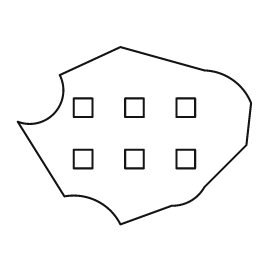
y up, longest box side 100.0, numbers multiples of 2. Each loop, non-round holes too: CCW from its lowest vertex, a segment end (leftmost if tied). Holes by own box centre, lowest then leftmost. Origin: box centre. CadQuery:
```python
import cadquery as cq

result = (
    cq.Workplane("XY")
    .moveTo(-6.0, -38.0)
    .lineTo(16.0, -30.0)
    .threePointArc((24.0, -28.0), (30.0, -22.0))
    .lineTo(48.0, -4.0)
    .lineTo(50.0, 14.0)
    .threePointArc((42.0, 24.0), (30.0, 28.0))
    .lineTo(-6.0, 38.0)
    .lineTo(-32.0, 26.0)
    .threePointArc((-34.0, 10.0), (-50.0, 6.0))
    .lineTo(-30.0, -26.0)
    .threePointArc((-16.0, -28.0), (-6.0, -38.0))
    .close()
    .moveTo(-26.0, -14.0)
    .lineTo(-18.0, -14.0)
    .lineTo(-18.0, -6.0)
    .lineTo(-26.0, -6.0)
    .close()
    .moveTo(-4.0, -14.0)
    .lineTo(4.0, -14.0)
    .lineTo(4.0, -6.0)
    .lineTo(-4.0, -6.0)
    .close()
    .moveTo(18.0, -14.0)
    .lineTo(26.0, -14.0)
    .lineTo(26.0, -6.0)
    .lineTo(18.0, -6.0)
    .close()
    .moveTo(-26.0, 8.0)
    .lineTo(-18.0, 8.0)
    .lineTo(-18.0, 16.0)
    .lineTo(-26.0, 16.0)
    .close()
    .moveTo(-4.0, 8.0)
    .lineTo(4.0, 8.0)
    .lineTo(4.0, 16.0)
    .lineTo(-4.0, 16.0)
    .close()
    .moveTo(18.0, 8.0)
    .lineTo(26.0, 8.0)
    .lineTo(26.0, 16.0)
    .lineTo(18.0, 16.0)
    .close()
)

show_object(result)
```